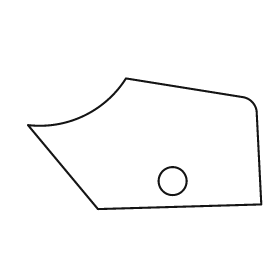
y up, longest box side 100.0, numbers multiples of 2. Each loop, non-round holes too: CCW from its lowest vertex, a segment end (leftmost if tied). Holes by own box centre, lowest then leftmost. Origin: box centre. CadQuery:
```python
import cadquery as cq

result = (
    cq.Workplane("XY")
    .moveTo(-20.0, -28.0)
    .lineTo(50.0, -26.0)
    .lineTo(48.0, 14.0)
    .threePointArc((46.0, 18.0), (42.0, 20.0))
    .lineTo(-8.0, 28.0)
    .threePointArc((-26.0, 12.0), (-50.0, 8.0))
    .close()
    .moveTo(12.0, -16.0)
    .circle(6.0)
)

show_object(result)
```